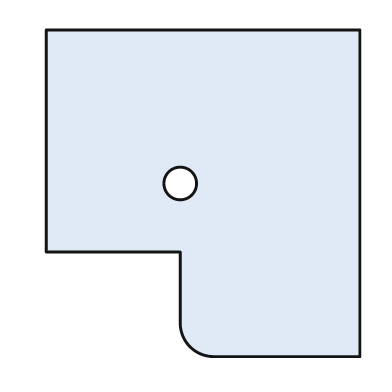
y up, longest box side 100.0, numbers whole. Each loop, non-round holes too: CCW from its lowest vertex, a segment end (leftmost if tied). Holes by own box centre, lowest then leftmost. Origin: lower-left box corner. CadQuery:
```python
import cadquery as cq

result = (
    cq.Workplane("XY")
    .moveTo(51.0, 0.0)
    .lineTo(96.0, 0.0)
    .lineTo(96.0, 100.0)
    .lineTo(0.0, 100.0)
    .lineTo(0.0, 32.0)
    .lineTo(41.0, 32.0)
    .lineTo(41.0, 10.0)
    .threePointArc((44.0, 3.0), (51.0, 0.0))
    .close()
    .moveTo(41.0, 53.0)
    .circle(5.0)
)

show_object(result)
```